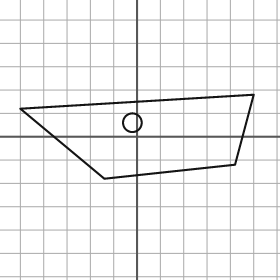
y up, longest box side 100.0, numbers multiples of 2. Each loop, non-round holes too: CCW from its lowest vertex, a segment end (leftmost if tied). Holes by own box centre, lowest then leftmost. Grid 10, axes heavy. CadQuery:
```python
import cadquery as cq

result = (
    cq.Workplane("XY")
    .moveTo(-14.0, -18.0)
    .lineTo(42.0, -12.0)
    .lineTo(50.0, 18.0)
    .lineTo(-50.0, 12.0)
    .close()
    .moveTo(-2.0, 6.0)
    .circle(4.0)
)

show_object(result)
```